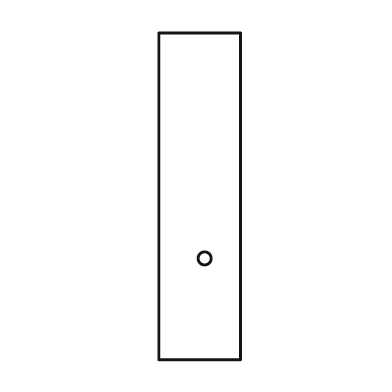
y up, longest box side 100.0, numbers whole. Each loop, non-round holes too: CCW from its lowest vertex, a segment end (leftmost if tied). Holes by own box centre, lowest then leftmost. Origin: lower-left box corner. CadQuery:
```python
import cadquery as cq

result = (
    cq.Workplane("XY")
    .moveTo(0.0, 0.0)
    .lineTo(25.0, 0.0)
    .lineTo(25.0, 100.0)
    .lineTo(0.0, 100.0)
    .close()
    .moveTo(14.0, 31.0)
    .circle(2.0)
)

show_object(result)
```